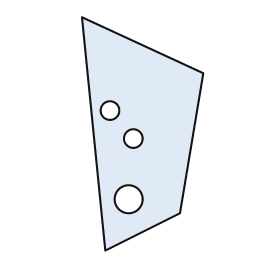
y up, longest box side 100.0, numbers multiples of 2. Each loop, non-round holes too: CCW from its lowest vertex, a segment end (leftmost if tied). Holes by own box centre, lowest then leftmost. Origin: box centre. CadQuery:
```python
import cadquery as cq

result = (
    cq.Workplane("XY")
    .moveTo(-16.0, -50.0)
    .lineTo(16.0, -34.0)
    .lineTo(26.0, 26.0)
    .lineTo(-26.0, 50.0)
    .close()
    .moveTo(-6.0, -28.0)
    .circle(6.0)
    .moveTo(-4.0, -2.0)
    .circle(4.0)
    .moveTo(-14.0, 10.0)
    .circle(4.0)
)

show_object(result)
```